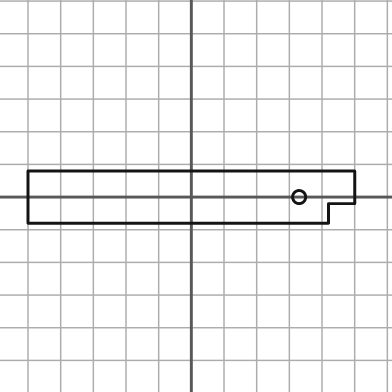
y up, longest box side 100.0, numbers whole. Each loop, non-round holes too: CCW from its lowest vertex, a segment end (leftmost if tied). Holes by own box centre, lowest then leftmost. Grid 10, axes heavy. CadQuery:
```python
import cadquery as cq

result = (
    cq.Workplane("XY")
    .moveTo(-50.0, -8.0)
    .lineTo(42.0, -8.0)
    .lineTo(42.0, -2.0)
    .lineTo(50.0, -2.0)
    .lineTo(50.0, 8.0)
    .lineTo(-50.0, 8.0)
    .close()
    .moveTo(33.0, 0.0)
    .circle(2.0)
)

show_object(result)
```